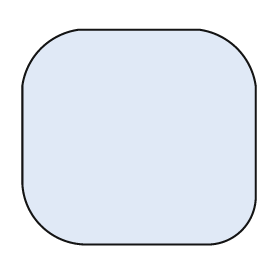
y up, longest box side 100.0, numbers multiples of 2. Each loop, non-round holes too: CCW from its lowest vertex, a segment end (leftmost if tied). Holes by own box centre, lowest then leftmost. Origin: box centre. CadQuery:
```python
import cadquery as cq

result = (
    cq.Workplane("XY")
    .moveTo(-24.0, -46.0)
    .lineTo(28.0, -46.0)
    .threePointArc((44.0, -40.0), (50.0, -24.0))
    .lineTo(50.0, 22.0)
    .threePointArc((42.0, 38.0), (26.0, 46.0))
    .lineTo(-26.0, 46.0)
    .threePointArc((-42.0, 38.0), (-50.0, 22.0))
    .lineTo(-50.0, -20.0)
    .threePointArc((-42.0, -38.0), (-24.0, -46.0))
    .close()
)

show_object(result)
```